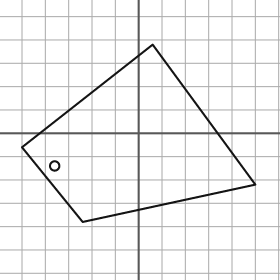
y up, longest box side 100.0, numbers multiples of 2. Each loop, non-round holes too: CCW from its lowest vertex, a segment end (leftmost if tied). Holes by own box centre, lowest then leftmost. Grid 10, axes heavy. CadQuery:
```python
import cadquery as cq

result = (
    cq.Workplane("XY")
    .moveTo(-24.0, -38.0)
    .lineTo(50.0, -22.0)
    .lineTo(6.0, 38.0)
    .lineTo(-50.0, -6.0)
    .close()
    .moveTo(-36.0, -14.0)
    .circle(2.0)
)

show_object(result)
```